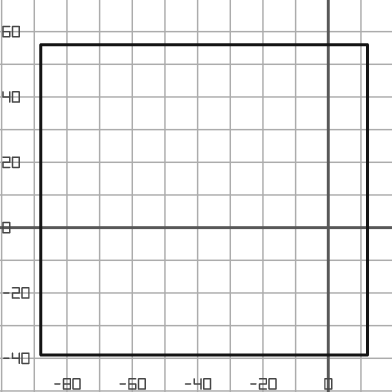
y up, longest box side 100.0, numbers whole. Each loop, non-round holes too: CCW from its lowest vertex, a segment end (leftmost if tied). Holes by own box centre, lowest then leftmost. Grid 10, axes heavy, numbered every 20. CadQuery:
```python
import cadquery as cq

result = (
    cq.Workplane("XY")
    .moveTo(-88.0, -39.0)
    .lineTo(12.0, -39.0)
    .lineTo(12.0, 56.0)
    .lineTo(-88.0, 56.0)
    .close()
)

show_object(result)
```